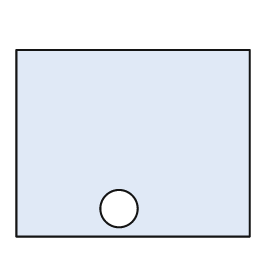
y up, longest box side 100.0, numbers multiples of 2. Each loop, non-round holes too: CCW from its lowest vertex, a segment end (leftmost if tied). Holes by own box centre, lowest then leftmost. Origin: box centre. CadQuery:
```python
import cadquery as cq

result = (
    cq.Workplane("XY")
    .moveTo(-50.0, -40.0)
    .lineTo(50.0, -40.0)
    .lineTo(50.0, 40.0)
    .lineTo(-50.0, 40.0)
    .close()
    .moveTo(-6.0, -28.0)
    .circle(8.0)
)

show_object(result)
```